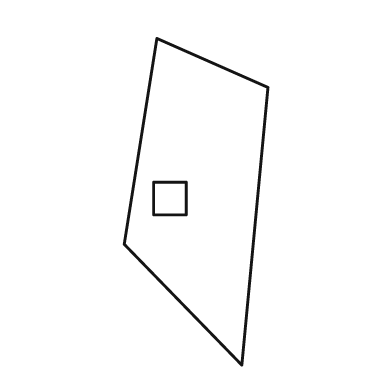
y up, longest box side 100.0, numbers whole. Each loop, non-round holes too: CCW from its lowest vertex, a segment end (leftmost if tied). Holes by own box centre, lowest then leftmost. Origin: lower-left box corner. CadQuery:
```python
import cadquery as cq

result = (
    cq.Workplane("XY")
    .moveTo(36.0, 0.0)
    .lineTo(44.0, 85.0)
    .lineTo(10.0, 100.0)
    .lineTo(0.0, 37.0)
    .close()
    .moveTo(9.0, 46.0)
    .lineTo(19.0, 46.0)
    .lineTo(19.0, 56.0)
    .lineTo(9.0, 56.0)
    .close()
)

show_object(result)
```